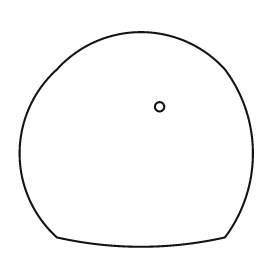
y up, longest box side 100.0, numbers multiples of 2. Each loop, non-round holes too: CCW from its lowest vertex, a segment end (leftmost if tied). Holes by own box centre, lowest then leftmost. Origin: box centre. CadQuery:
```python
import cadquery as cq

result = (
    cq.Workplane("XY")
    .moveTo(-34.0, -42.0)
    .threePointArc((2.0, -46.0), (38.0, -42.0))
    .threePointArc((50.0, -6.0), (38.0, 30.0))
    .threePointArc((2.0, 46.0), (-34.0, 30.0))
    .threePointArc((-50.0, -6.0), (-34.0, -42.0))
    .close()
    .moveTo(10.0, 14.0)
    .circle(2.0)
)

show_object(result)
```